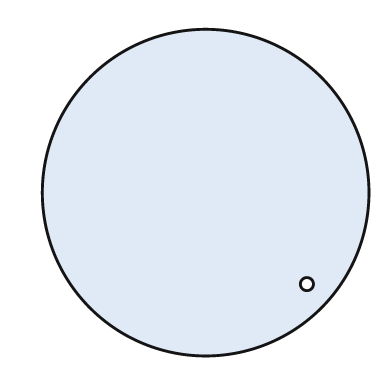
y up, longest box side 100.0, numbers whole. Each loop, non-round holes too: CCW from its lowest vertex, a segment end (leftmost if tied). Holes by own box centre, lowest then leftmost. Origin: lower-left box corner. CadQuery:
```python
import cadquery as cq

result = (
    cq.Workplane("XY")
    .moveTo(50.0, 50.0)
    .circle(50.0)
    .moveTo(81.0, 22.0)
    .circle(2.0)
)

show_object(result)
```